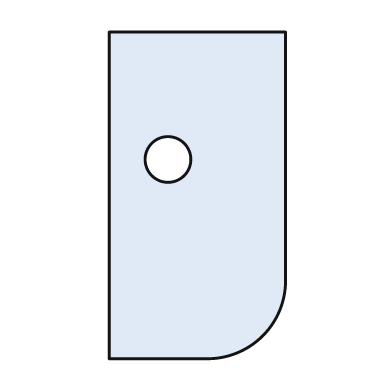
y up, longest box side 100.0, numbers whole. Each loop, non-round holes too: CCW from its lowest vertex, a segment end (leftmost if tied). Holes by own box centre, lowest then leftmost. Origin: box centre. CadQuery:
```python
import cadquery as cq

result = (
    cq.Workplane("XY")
    .moveTo(-27.0, -50.0)
    .lineTo(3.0, -50.0)
    .threePointArc((20.0, -43.0), (27.0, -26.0))
    .lineTo(27.0, 50.0)
    .lineTo(-27.0, 50.0)
    .close()
    .moveTo(-9.0, 11.0)
    .circle(7.0)
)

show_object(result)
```